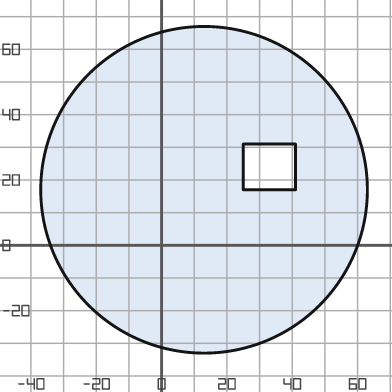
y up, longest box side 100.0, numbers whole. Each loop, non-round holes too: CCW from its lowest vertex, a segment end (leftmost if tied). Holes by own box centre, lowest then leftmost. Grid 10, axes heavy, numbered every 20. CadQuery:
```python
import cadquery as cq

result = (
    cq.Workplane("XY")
    .moveTo(13.0, 17.0)
    .circle(50.0)
    .moveTo(25.0, 17.0)
    .lineTo(41.0, 17.0)
    .lineTo(41.0, 31.0)
    .lineTo(25.0, 31.0)
    .close()
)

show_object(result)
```